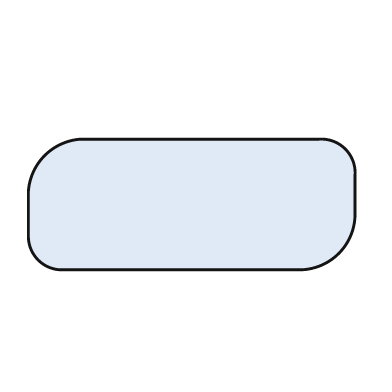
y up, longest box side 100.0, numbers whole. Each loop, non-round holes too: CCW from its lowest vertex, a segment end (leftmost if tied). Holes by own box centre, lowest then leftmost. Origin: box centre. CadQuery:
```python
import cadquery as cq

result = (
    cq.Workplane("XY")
    .moveTo(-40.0, -20.0)
    .lineTo(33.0, -20.0)
    .threePointArc((45.0, -15.0), (50.0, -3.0))
    .lineTo(50.0, 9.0)
    .threePointArc((47.0, 17.0), (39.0, 20.0))
    .lineTo(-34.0, 20.0)
    .threePointArc((-45.0, 15.0), (-50.0, 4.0))
    .lineTo(-50.0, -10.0)
    .threePointArc((-47.0, -17.0), (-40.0, -20.0))
    .close()
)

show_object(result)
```